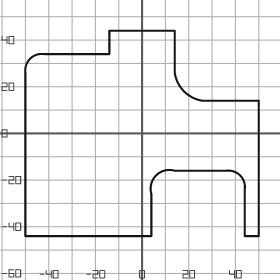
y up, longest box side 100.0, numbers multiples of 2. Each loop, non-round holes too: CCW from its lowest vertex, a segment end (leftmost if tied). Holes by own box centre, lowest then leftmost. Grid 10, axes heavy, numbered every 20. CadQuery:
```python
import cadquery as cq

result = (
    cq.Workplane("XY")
    .moveTo(-50.0, -44.0)
    .lineTo(4.0, -44.0)
    .lineTo(4.0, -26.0)
    .threePointArc((6.0, -18.0), (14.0, -16.0))
    .lineTo(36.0, -16.0)
    .threePointArc((42.0, -18.0), (44.0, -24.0))
    .lineTo(44.0, -44.0)
    .lineTo(50.0, -44.0)
    .lineTo(50.0, 14.0)
    .lineTo(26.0, 14.0)
    .threePointArc((18.0, 18.0), (14.0, 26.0))
    .lineTo(14.0, 44.0)
    .lineTo(-14.0, 44.0)
    .lineTo(-14.0, 34.0)
    .lineTo(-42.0, 34.0)
    .threePointArc((-48.0, 32.0), (-50.0, 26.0))
    .close()
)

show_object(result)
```